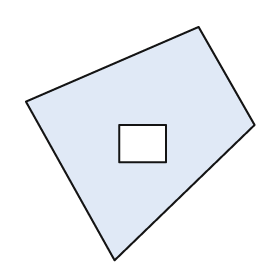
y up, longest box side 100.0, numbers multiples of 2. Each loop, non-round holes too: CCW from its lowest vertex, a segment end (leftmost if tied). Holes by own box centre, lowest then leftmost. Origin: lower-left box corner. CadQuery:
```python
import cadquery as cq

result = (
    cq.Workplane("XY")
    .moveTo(38.0, 0.0)
    .lineTo(98.0, 58.0)
    .lineTo(74.0, 100.0)
    .lineTo(0.0, 68.0)
    .close()
    .moveTo(40.0, 42.0)
    .lineTo(60.0, 42.0)
    .lineTo(60.0, 58.0)
    .lineTo(40.0, 58.0)
    .close()
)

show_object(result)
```